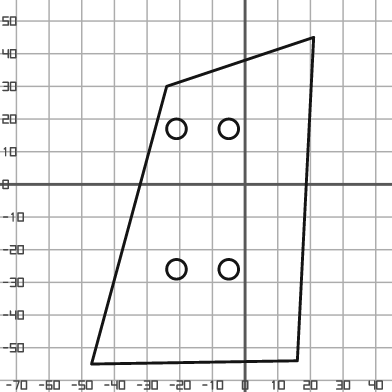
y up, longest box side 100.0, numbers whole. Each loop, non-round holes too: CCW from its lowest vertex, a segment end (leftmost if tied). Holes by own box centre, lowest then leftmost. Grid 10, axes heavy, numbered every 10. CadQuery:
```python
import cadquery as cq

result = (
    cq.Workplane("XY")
    .moveTo(-47.0, -55.0)
    .lineTo(16.0, -54.0)
    .lineTo(21.0, 45.0)
    .lineTo(-24.0, 30.0)
    .close()
    .moveTo(-21.0, -26.0)
    .circle(3.0)
    .moveTo(-5.0, -26.0)
    .circle(3.0)
    .moveTo(-21.0, 17.0)
    .circle(3.0)
    .moveTo(-5.0, 17.0)
    .circle(3.0)
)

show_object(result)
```